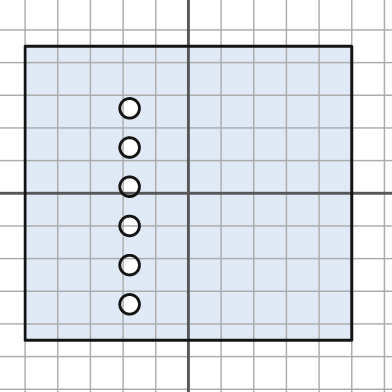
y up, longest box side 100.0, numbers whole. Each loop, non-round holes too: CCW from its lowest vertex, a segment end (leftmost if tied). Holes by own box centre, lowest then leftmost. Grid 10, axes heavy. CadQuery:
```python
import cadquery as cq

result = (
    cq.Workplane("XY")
    .moveTo(-50.0, -45.0)
    .lineTo(50.0, -45.0)
    .lineTo(50.0, 45.0)
    .lineTo(-50.0, 45.0)
    .close()
    .moveTo(-18.0, -34.0)
    .circle(3.0)
    .moveTo(-18.0, -22.0)
    .circle(3.0)
    .moveTo(-18.0, -10.0)
    .circle(3.0)
    .moveTo(-18.0, 2.0)
    .circle(3.0)
    .moveTo(-18.0, 14.0)
    .circle(3.0)
    .moveTo(-18.0, 26.0)
    .circle(3.0)
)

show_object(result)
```